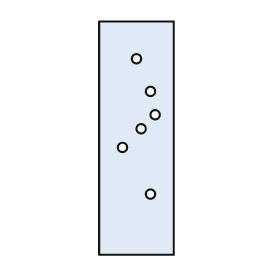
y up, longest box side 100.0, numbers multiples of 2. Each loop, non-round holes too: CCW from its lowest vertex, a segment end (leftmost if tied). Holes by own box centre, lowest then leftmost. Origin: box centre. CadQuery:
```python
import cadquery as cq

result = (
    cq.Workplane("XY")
    .moveTo(-16.0, -50.0)
    .lineTo(16.0, -50.0)
    .lineTo(16.0, 50.0)
    .lineTo(-16.0, 50.0)
    .close()
    .moveTo(6.0, -24.0)
    .circle(2.0)
    .moveTo(-6.0, -4.0)
    .circle(2.0)
    .moveTo(2.0, 4.0)
    .circle(2.0)
    .moveTo(8.0, 10.0)
    .circle(2.0)
    .moveTo(6.0, 20.0)
    .circle(2.0)
    .moveTo(0.0, 34.0)
    .circle(2.0)
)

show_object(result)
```